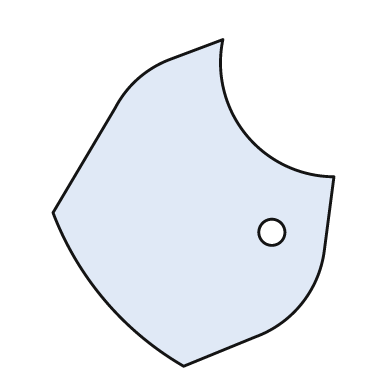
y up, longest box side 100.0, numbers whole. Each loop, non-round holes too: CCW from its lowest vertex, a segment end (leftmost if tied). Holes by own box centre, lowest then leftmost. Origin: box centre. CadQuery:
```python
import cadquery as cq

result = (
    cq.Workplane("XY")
    .moveTo(-3.0, -50.0)
    .lineTo(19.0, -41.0)
    .threePointArc((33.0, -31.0), (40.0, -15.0))
    .lineTo(43.0, 8.0)
    .threePointArc((16.0, 21.0), (9.0, 50.0))
    .lineTo(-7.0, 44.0)
    .threePointArc((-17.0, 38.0), (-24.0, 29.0))
    .lineTo(-43.0, -3.0)
    .threePointArc((-27.0, -30.0), (-3.0, -50.0))
    .close()
    .moveTo(24.0, -9.0)
    .circle(4.0)
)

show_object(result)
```